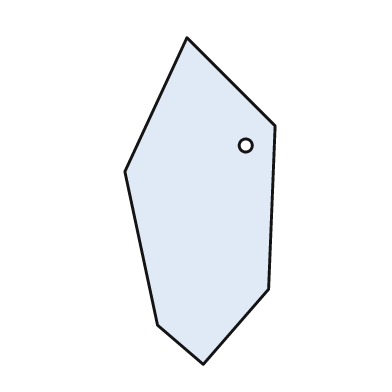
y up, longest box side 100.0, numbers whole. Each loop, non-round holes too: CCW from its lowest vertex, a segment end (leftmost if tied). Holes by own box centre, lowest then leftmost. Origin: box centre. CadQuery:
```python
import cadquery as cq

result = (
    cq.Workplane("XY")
    .moveTo(1.0, -50.0)
    .lineTo(21.0, -27.0)
    .lineTo(23.0, 23.0)
    .lineTo(-4.0, 50.0)
    .lineTo(-23.0, 9.0)
    .lineTo(-13.0, -38.0)
    .close()
    .moveTo(14.0, 17.0)
    .circle(2.0)
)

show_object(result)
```